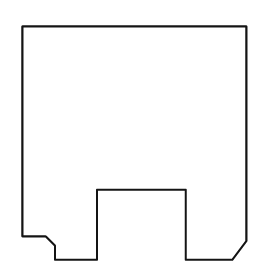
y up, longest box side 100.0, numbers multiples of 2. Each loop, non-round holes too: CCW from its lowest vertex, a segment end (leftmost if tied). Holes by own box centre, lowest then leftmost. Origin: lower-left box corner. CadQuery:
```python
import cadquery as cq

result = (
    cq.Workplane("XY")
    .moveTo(14.0, 0.0)
    .lineTo(32.0, 0.0)
    .lineTo(32.0, 30.0)
    .lineTo(70.0, 30.0)
    .lineTo(70.0, 0.0)
    .lineTo(90.0, 0.0)
    .lineTo(96.0, 8.0)
    .lineTo(96.0, 100.0)
    .lineTo(0.0, 100.0)
    .lineTo(0.0, 10.0)
    .lineTo(10.0, 10.0)
    .lineTo(14.0, 6.0)
    .close()
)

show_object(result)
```